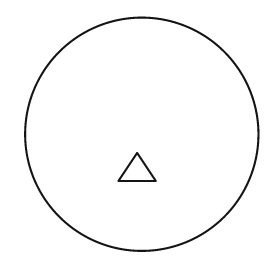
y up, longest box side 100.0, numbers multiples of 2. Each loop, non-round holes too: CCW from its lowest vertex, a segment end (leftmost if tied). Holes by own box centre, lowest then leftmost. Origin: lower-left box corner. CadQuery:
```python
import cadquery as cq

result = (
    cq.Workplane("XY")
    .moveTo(50.0, 50.0)
    .circle(50.0)
    .moveTo(40.0, 30.0)
    .lineTo(56.0, 30.0)
    .lineTo(48.0, 42.0)
    .close()
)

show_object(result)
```